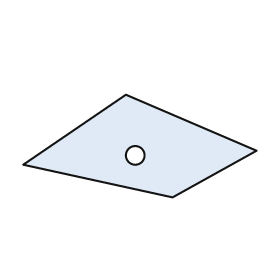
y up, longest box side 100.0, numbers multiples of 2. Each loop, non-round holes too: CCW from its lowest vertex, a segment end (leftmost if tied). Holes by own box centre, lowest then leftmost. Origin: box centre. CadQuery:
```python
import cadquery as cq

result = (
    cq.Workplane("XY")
    .moveTo(14.0, -22.0)
    .lineTo(50.0, -2.0)
    .lineTo(-6.0, 22.0)
    .lineTo(-50.0, -8.0)
    .close()
    .moveTo(-2.0, -4.0)
    .circle(4.0)
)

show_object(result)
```